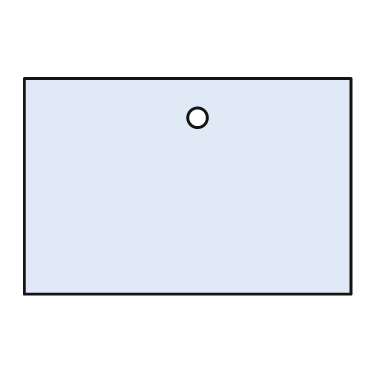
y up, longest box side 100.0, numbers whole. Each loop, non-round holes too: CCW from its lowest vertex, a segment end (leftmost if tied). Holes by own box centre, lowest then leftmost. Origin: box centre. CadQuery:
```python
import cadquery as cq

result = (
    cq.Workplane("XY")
    .moveTo(-50.0, -33.0)
    .lineTo(50.0, -33.0)
    .lineTo(50.0, 33.0)
    .lineTo(-50.0, 33.0)
    .close()
    .moveTo(3.0, 21.0)
    .circle(3.0)
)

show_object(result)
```